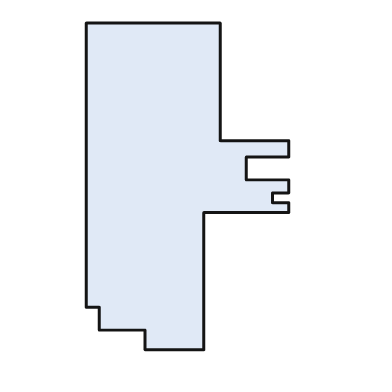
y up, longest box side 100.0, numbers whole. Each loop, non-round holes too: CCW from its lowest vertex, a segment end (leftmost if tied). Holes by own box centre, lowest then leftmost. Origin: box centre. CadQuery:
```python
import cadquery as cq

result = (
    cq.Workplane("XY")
    .moveTo(-13.0, -50.0)
    .lineTo(5.0, -50.0)
    .lineTo(5.0, -8.0)
    .lineTo(31.0, -8.0)
    .lineTo(31.0, -5.0)
    .lineTo(26.0, -5.0)
    .lineTo(26.0, -2.0)
    .lineTo(31.0, -2.0)
    .lineTo(31.0, 2.0)
    .lineTo(18.0, 2.0)
    .lineTo(18.0, 9.0)
    .lineTo(31.0, 9.0)
    .lineTo(31.0, 14.0)
    .lineTo(10.0, 14.0)
    .lineTo(10.0, 50.0)
    .lineTo(-31.0, 50.0)
    .lineTo(-31.0, -37.0)
    .lineTo(-27.0, -37.0)
    .lineTo(-27.0, -44.0)
    .lineTo(-13.0, -44.0)
    .close()
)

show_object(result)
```